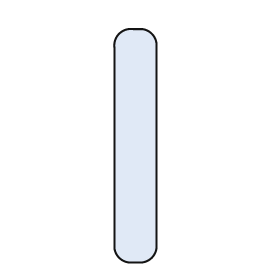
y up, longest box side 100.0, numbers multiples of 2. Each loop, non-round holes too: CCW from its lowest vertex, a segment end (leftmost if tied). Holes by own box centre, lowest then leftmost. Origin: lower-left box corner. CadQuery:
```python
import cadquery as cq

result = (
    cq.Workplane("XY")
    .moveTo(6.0, 0.0)
    .lineTo(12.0, 0.0)
    .threePointArc((16.0, 2.0), (18.0, 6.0))
    .lineTo(18.0, 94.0)
    .threePointArc((16.0, 98.0), (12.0, 100.0))
    .lineTo(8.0, 100.0)
    .threePointArc((2.0, 98.0), (0.0, 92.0))
    .lineTo(0.0, 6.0)
    .threePointArc((2.0, 2.0), (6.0, 0.0))
    .close()
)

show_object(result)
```